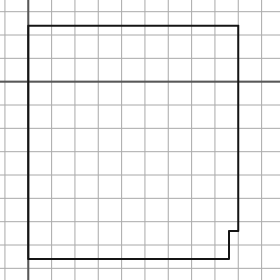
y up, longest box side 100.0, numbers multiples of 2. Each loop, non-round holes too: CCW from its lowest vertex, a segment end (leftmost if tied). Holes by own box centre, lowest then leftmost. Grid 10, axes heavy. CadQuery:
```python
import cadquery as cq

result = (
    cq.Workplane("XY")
    .moveTo(0.0, -76.0)
    .lineTo(86.0, -76.0)
    .lineTo(86.0, -64.0)
    .lineTo(90.0, -64.0)
    .lineTo(90.0, 24.0)
    .lineTo(0.0, 24.0)
    .close()
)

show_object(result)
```